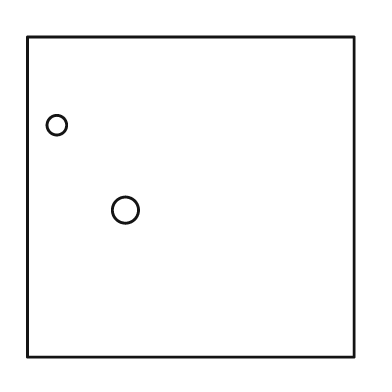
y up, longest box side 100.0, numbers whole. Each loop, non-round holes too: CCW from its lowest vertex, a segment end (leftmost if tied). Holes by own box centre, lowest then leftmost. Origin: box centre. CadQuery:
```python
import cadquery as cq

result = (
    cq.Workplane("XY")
    .moveTo(-50.0, -49.0)
    .lineTo(50.0, -49.0)
    .lineTo(50.0, 49.0)
    .lineTo(-50.0, 49.0)
    .close()
    .moveTo(-20.0, -4.0)
    .circle(4.0)
    .moveTo(-41.0, 22.0)
    .circle(3.0)
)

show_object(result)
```